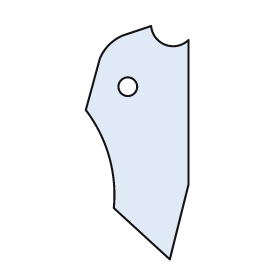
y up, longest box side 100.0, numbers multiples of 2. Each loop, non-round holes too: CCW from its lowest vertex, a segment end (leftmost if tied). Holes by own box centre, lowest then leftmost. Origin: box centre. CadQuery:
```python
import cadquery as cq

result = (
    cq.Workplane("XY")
    .moveTo(14.0, -50.0)
    .lineTo(22.0, -18.0)
    .lineTo(22.0, 44.0)
    .threePointArc((12.0, 42.0), (6.0, 50.0))
    .lineTo(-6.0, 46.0)
    .threePointArc((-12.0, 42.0), (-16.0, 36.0))
    .lineTo(-22.0, 14.0)
    .threePointArc((-12.0, -6.0), (-10.0, -28.0))
    .close()
    .moveTo(-4.0, 24.0)
    .circle(4.0)
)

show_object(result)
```